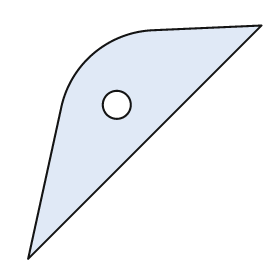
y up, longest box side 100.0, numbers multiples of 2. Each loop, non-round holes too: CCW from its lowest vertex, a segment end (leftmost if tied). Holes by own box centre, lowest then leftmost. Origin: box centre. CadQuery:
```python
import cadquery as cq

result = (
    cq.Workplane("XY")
    .moveTo(-50.0, -50.0)
    .lineTo(50.0, 50.0)
    .lineTo(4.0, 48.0)
    .threePointArc((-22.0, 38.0), (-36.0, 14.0))
    .close()
    .moveTo(-12.0, 16.0)
    .circle(6.0)
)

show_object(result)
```